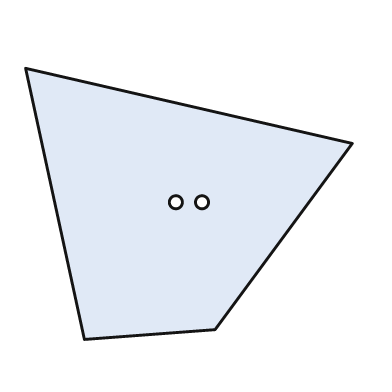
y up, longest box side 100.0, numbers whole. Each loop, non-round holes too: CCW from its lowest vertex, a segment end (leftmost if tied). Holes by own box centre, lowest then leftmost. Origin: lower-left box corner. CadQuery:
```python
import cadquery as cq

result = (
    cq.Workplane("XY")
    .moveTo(18.0, 0.0)
    .lineTo(58.0, 3.0)
    .lineTo(100.0, 60.0)
    .lineTo(0.0, 83.0)
    .close()
    .moveTo(46.0, 42.0)
    .circle(2.0)
    .moveTo(54.0, 42.0)
    .circle(2.0)
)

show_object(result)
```